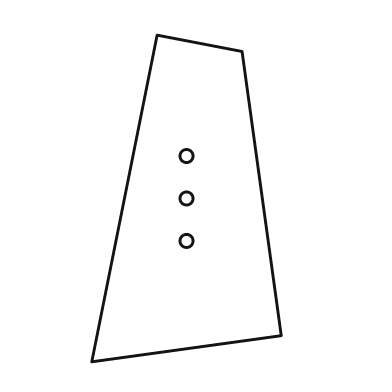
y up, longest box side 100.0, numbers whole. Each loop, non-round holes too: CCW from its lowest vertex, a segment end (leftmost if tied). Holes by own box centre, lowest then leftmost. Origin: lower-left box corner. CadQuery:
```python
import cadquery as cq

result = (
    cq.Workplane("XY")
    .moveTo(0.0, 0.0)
    .lineTo(58.0, 8.0)
    .lineTo(46.0, 95.0)
    .lineTo(20.0, 100.0)
    .close()
    .moveTo(29.0, 37.0)
    .circle(2.0)
    .moveTo(29.0, 50.0)
    .circle(2.0)
    .moveTo(29.0, 63.0)
    .circle(2.0)
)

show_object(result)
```